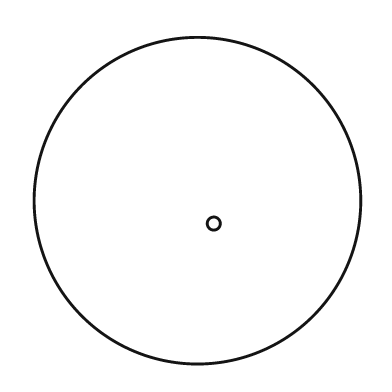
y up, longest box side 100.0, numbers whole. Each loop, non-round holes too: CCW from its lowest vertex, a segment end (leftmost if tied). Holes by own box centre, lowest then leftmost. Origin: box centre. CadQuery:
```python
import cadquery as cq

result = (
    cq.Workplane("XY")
    .moveTo(0.0, 0.0)
    .circle(50.0)
    .moveTo(5.0, -7.0)
    .circle(2.0)
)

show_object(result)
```